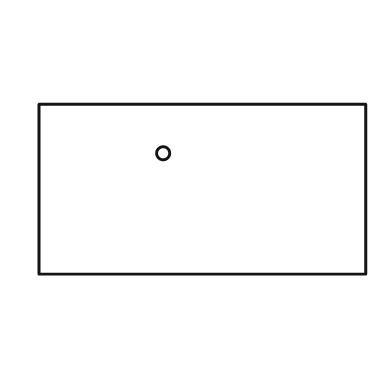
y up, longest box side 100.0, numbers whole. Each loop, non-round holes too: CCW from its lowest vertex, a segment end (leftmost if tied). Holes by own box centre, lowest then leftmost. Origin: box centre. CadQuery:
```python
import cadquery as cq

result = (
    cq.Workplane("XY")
    .moveTo(-50.0, -26.0)
    .lineTo(50.0, -26.0)
    .lineTo(50.0, 26.0)
    .lineTo(-50.0, 26.0)
    .close()
    .moveTo(-12.0, 11.0)
    .circle(2.0)
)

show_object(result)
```